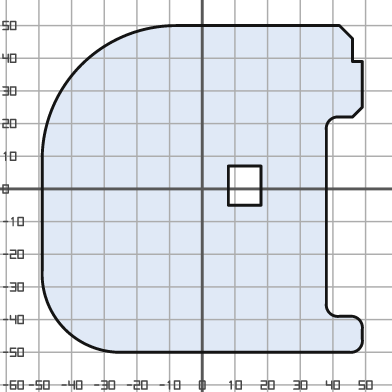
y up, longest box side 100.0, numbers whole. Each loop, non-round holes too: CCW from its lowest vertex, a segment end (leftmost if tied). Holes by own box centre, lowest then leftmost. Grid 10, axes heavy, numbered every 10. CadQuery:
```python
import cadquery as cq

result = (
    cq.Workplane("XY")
    .moveTo(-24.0, -50.0)
    .lineTo(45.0, -50.0)
    .threePointArc((48.0, -49.0), (49.0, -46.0))
    .lineTo(49.0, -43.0)
    .threePointArc((48.0, -40.0), (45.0, -39.0))
    .lineTo(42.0, -39.0)
    .threePointArc((39.0, -38.0), (38.0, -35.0))
    .lineTo(38.0, 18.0)
    .threePointArc((39.0, 21.0), (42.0, 22.0))
    .lineTo(46.0, 22.0)
    .lineTo(49.0, 25.0)
    .lineTo(49.0, 39.0)
    .lineTo(46.0, 39.0)
    .lineTo(46.0, 46.0)
    .lineTo(42.0, 50.0)
    .lineTo(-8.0, 50.0)
    .threePointArc((-37.0, 38.0), (-49.0, 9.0))
    .lineTo(-49.0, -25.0)
    .threePointArc((-42.0, -43.0), (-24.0, -50.0))
    .close()
    .moveTo(8.0, -5.0)
    .lineTo(18.0, -5.0)
    .lineTo(18.0, 7.0)
    .lineTo(8.0, 7.0)
    .close()
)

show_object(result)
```